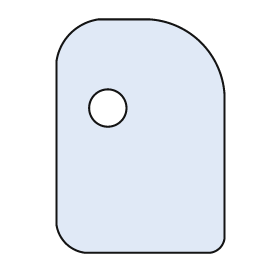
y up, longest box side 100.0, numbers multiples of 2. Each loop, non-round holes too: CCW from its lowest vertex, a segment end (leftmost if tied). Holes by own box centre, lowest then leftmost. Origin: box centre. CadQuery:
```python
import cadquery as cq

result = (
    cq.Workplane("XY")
    .moveTo(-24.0, -50.0)
    .lineTo(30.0, -50.0)
    .threePointArc((34.0, -48.0), (36.0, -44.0))
    .lineTo(36.0, 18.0)
    .threePointArc((26.0, 40.0), (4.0, 50.0))
    .lineTo(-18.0, 50.0)
    .threePointArc((-30.0, 44.0), (-36.0, 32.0))
    .lineTo(-36.0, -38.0)
    .threePointArc((-32.0, -46.0), (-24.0, -50.0))
    .close()
    .moveTo(-14.0, 12.0)
    .circle(8.0)
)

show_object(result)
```